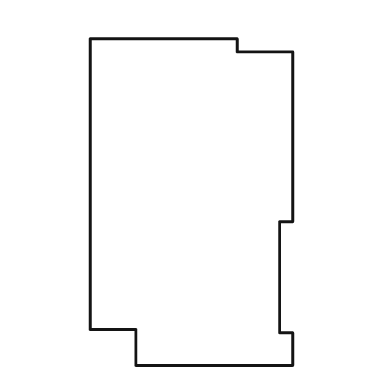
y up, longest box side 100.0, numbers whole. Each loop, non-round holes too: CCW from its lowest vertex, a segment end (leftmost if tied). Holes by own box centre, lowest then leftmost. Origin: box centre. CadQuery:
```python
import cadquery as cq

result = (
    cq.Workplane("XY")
    .moveTo(-17.0, -50.0)
    .lineTo(31.0, -50.0)
    .lineTo(31.0, -40.0)
    .lineTo(27.0, -40.0)
    .lineTo(27.0, -6.0)
    .lineTo(31.0, -6.0)
    .lineTo(31.0, 46.0)
    .lineTo(14.0, 46.0)
    .lineTo(14.0, 50.0)
    .lineTo(-31.0, 50.0)
    .lineTo(-31.0, -39.0)
    .lineTo(-17.0, -39.0)
    .close()
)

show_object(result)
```